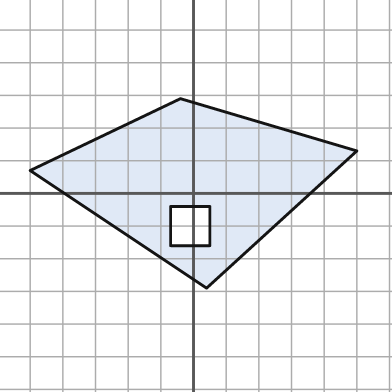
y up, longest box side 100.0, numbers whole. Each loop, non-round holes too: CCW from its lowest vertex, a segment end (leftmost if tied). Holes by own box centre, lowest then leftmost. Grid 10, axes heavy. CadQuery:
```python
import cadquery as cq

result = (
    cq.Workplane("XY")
    .moveTo(4.0, -29.0)
    .lineTo(50.0, 13.0)
    .lineTo(-4.0, 29.0)
    .lineTo(-50.0, 7.0)
    .close()
    .moveTo(-7.0, -16.0)
    .lineTo(5.0, -16.0)
    .lineTo(5.0, -4.0)
    .lineTo(-7.0, -4.0)
    .close()
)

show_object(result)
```